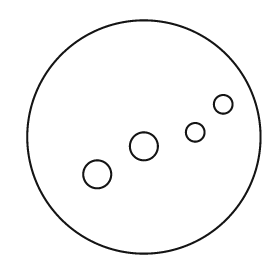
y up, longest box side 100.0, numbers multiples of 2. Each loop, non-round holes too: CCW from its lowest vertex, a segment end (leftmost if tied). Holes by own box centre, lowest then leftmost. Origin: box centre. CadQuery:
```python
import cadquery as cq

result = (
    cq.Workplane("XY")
    .moveTo(0.0, 0.0)
    .circle(50.0)
    .moveTo(-20.0, -16.0)
    .circle(6.0)
    .moveTo(0.0, -4.0)
    .circle(6.0)
    .moveTo(22.0, 2.0)
    .circle(4.0)
    .moveTo(34.0, 14.0)
    .circle(4.0)
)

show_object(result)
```